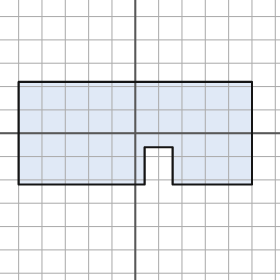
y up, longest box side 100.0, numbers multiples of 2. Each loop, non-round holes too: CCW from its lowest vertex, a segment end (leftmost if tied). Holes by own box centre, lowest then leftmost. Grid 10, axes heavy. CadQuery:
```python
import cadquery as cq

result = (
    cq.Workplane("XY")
    .moveTo(-50.0, -22.0)
    .lineTo(4.0, -22.0)
    .lineTo(4.0, -6.0)
    .lineTo(16.0, -6.0)
    .lineTo(16.0, -22.0)
    .lineTo(50.0, -22.0)
    .lineTo(50.0, 22.0)
    .lineTo(-50.0, 22.0)
    .close()
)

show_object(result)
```